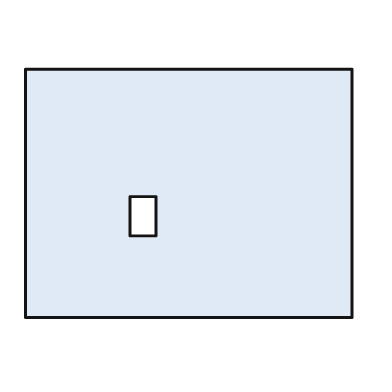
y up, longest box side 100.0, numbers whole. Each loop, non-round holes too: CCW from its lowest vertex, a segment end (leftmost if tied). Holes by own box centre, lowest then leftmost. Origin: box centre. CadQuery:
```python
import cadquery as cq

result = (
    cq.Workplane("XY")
    .moveTo(-50.0, -38.0)
    .lineTo(50.0, -38.0)
    .lineTo(50.0, 38.0)
    .lineTo(-50.0, 38.0)
    .close()
    .moveTo(-18.0, -13.0)
    .lineTo(-10.0, -13.0)
    .lineTo(-10.0, -1.0)
    .lineTo(-18.0, -1.0)
    .close()
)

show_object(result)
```